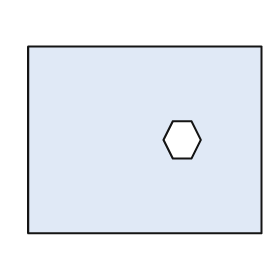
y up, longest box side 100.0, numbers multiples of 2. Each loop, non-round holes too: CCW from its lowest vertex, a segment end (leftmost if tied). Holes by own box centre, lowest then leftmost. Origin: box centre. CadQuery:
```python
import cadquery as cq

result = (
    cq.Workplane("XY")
    .moveTo(-50.0, -40.0)
    .lineTo(50.0, -40.0)
    .lineTo(50.0, 40.0)
    .lineTo(-50.0, 40.0)
    .close()
    .moveTo(12.0, -8.0)
    .lineTo(20.0, -8.0)
    .lineTo(24.0, 0.0)
    .lineTo(20.0, 8.0)
    .lineTo(12.0, 8.0)
    .lineTo(8.0, 0.0)
    .close()
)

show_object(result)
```